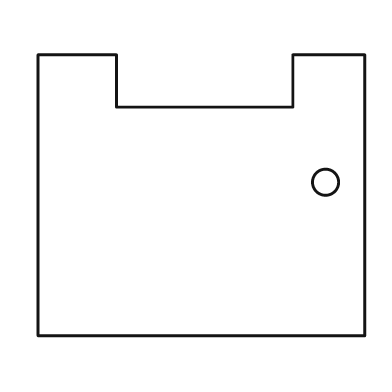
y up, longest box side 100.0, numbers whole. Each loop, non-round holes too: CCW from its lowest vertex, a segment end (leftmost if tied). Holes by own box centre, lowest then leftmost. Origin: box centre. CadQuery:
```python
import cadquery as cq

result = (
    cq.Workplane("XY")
    .moveTo(-50.0, -43.0)
    .lineTo(50.0, -43.0)
    .lineTo(50.0, 43.0)
    .lineTo(28.0, 43.0)
    .lineTo(28.0, 27.0)
    .lineTo(-26.0, 27.0)
    .lineTo(-26.0, 43.0)
    .lineTo(-50.0, 43.0)
    .close()
    .moveTo(38.0, 4.0)
    .circle(4.0)
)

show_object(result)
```